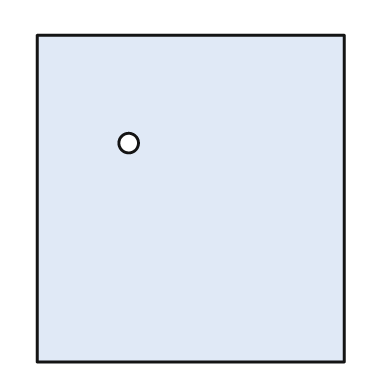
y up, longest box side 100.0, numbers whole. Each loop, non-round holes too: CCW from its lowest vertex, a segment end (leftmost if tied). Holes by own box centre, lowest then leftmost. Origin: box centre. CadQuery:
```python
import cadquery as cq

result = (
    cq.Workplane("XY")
    .moveTo(-47.0, -50.0)
    .lineTo(47.0, -50.0)
    .lineTo(47.0, 50.0)
    .lineTo(-47.0, 50.0)
    .close()
    .moveTo(-19.0, 17.0)
    .circle(3.0)
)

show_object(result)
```